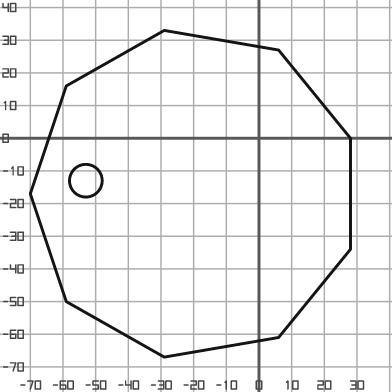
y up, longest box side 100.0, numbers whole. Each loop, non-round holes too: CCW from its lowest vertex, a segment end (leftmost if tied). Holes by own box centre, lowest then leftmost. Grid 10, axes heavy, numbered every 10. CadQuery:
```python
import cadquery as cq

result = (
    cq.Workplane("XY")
    .moveTo(-29.0, -67.0)
    .lineTo(6.0, -61.0)
    .lineTo(28.0, -34.0)
    .lineTo(28.0, 0.0)
    .lineTo(6.0, 27.0)
    .lineTo(-29.0, 33.0)
    .lineTo(-59.0, 16.0)
    .lineTo(-70.0, -17.0)
    .lineTo(-59.0, -50.0)
    .close()
    .moveTo(-53.0, -13.0)
    .circle(5.0)
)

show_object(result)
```